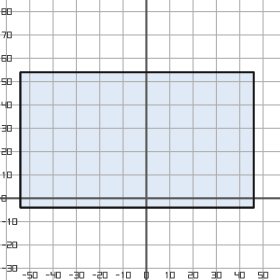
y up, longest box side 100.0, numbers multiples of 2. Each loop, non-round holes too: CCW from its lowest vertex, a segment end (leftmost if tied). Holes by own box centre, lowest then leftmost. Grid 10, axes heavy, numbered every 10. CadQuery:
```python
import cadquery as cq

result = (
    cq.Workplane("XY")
    .moveTo(-54.0, -4.0)
    .lineTo(46.0, -4.0)
    .lineTo(46.0, 54.0)
    .lineTo(-54.0, 54.0)
    .close()
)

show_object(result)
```